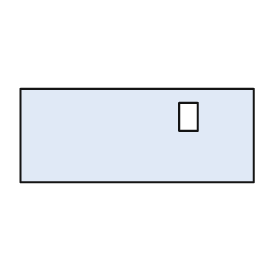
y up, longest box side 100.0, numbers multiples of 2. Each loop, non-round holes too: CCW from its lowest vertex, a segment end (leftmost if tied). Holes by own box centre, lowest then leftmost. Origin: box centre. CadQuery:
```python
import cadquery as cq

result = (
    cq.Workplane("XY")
    .moveTo(-50.0, -20.0)
    .lineTo(50.0, -20.0)
    .lineTo(50.0, 20.0)
    .lineTo(-50.0, 20.0)
    .close()
    .moveTo(18.0, 2.0)
    .lineTo(26.0, 2.0)
    .lineTo(26.0, 14.0)
    .lineTo(18.0, 14.0)
    .close()
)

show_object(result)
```